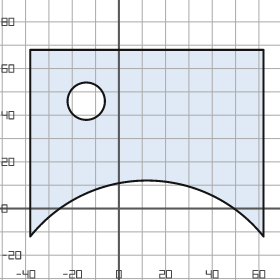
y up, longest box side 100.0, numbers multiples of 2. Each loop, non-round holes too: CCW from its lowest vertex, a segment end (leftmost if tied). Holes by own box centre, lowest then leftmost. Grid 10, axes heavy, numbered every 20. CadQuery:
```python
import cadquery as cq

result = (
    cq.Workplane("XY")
    .moveTo(-38.0, -12.0)
    .threePointArc((12.0, 12.0), (62.0, -12.0))
    .lineTo(62.0, 68.0)
    .lineTo(-38.0, 68.0)
    .close()
    .moveTo(-14.0, 46.0)
    .circle(8.0)
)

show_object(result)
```